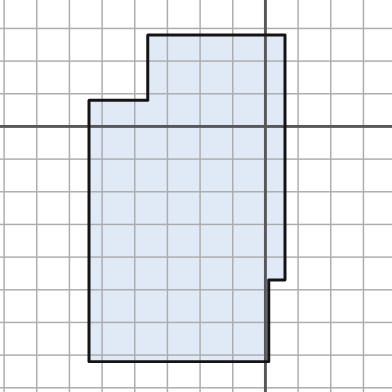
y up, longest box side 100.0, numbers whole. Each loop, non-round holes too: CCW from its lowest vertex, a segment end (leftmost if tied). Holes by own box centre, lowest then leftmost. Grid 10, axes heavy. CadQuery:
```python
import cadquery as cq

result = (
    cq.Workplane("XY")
    .moveTo(-54.0, -72.0)
    .lineTo(1.0, -72.0)
    .lineTo(1.0, -47.0)
    .lineTo(6.0, -47.0)
    .lineTo(6.0, 28.0)
    .lineTo(-36.0, 28.0)
    .lineTo(-36.0, 8.0)
    .lineTo(-54.0, 8.0)
    .close()
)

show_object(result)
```